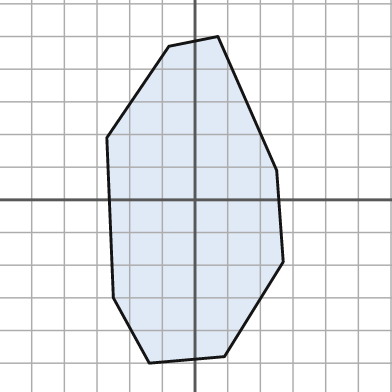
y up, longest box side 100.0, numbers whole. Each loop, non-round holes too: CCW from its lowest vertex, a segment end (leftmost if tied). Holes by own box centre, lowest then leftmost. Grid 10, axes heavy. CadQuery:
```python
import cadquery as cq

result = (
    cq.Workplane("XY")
    .moveTo(-14.0, -50.0)
    .lineTo(9.0, -48.0)
    .lineTo(27.0, -19.0)
    .lineTo(25.0, 9.0)
    .lineTo(7.0, 50.0)
    .lineTo(-8.0, 47.0)
    .lineTo(-27.0, 19.0)
    .lineTo(-25.0, -30.0)
    .close()
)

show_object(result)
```